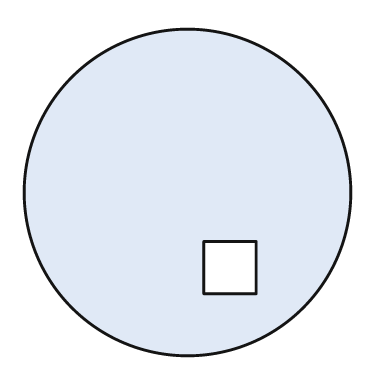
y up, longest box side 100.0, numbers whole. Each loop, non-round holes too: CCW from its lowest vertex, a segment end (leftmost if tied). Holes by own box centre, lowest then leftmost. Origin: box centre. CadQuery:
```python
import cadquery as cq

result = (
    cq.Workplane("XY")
    .moveTo(0.0, 0.0)
    .circle(50.0)
    .moveTo(5.0, -31.0)
    .lineTo(21.0, -31.0)
    .lineTo(21.0, -15.0)
    .lineTo(5.0, -15.0)
    .close()
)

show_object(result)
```